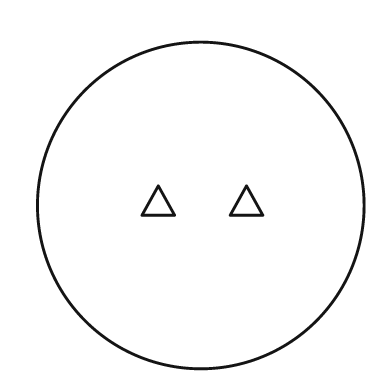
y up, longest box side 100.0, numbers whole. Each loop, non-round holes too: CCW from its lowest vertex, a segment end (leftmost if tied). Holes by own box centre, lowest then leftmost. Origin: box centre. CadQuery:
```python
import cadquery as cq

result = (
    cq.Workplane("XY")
    .moveTo(0.0, 0.0)
    .circle(50.0)
    .moveTo(-18.0, -3.0)
    .lineTo(-8.0, -3.0)
    .lineTo(-13.0, 6.0)
    .close()
    .moveTo(9.0, -3.0)
    .lineTo(19.0, -3.0)
    .lineTo(14.0, 6.0)
    .close()
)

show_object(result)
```